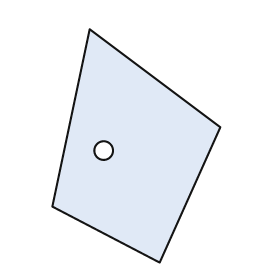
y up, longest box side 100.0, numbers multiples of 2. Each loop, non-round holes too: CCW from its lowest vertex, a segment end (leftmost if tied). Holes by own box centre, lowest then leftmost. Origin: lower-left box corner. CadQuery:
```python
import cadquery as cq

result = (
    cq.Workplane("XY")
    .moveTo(46.0, 0.0)
    .lineTo(72.0, 58.0)
    .lineTo(16.0, 100.0)
    .lineTo(0.0, 24.0)
    .close()
    .moveTo(22.0, 48.0)
    .circle(4.0)
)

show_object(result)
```